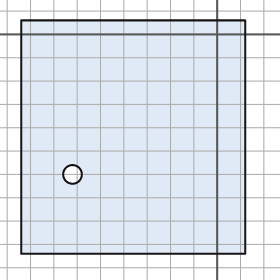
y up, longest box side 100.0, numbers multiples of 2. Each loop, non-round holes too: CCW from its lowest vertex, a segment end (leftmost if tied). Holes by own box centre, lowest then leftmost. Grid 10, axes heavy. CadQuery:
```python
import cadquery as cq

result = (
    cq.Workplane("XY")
    .moveTo(-84.0, -94.0)
    .lineTo(12.0, -94.0)
    .lineTo(12.0, 6.0)
    .lineTo(-84.0, 6.0)
    .close()
    .moveTo(-62.0, -60.0)
    .circle(4.0)
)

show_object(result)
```